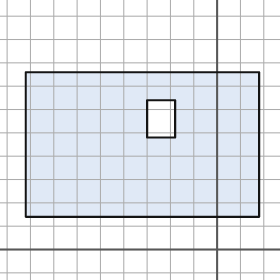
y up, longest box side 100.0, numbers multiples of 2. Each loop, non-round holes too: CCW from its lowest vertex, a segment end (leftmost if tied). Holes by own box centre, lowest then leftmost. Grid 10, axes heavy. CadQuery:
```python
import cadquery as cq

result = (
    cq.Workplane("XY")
    .moveTo(-82.0, 14.0)
    .lineTo(18.0, 14.0)
    .lineTo(18.0, 76.0)
    .lineTo(-82.0, 76.0)
    .close()
    .moveTo(-30.0, 48.0)
    .lineTo(-18.0, 48.0)
    .lineTo(-18.0, 64.0)
    .lineTo(-30.0, 64.0)
    .close()
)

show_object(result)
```